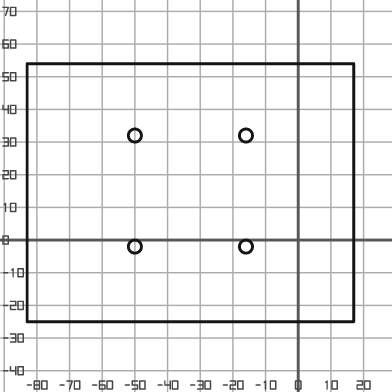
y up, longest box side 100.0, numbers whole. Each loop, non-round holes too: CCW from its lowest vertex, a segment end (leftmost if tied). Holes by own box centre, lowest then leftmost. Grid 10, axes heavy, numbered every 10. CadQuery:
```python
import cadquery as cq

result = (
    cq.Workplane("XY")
    .moveTo(-83.0, -25.0)
    .lineTo(17.0, -25.0)
    .lineTo(17.0, 54.0)
    .lineTo(-83.0, 54.0)
    .close()
    .moveTo(-50.0, -2.0)
    .circle(2.0)
    .moveTo(-16.0, -2.0)
    .circle(2.0)
    .moveTo(-50.0, 32.0)
    .circle(2.0)
    .moveTo(-16.0, 32.0)
    .circle(2.0)
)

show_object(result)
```